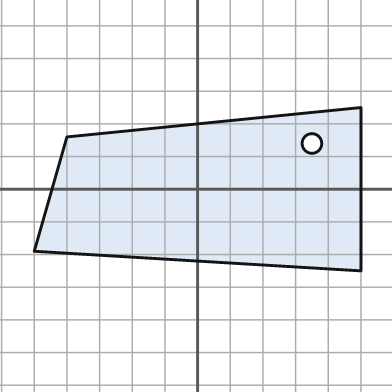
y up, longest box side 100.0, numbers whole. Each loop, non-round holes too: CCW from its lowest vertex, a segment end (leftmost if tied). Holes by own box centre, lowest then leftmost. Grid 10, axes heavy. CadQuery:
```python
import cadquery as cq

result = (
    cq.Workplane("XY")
    .moveTo(50.0, -25.0)
    .lineTo(50.0, 25.0)
    .lineTo(-40.0, 16.0)
    .lineTo(-50.0, -19.0)
    .close()
    .moveTo(35.0, 14.0)
    .circle(3.0)
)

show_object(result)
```